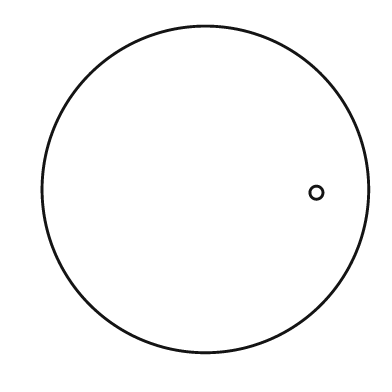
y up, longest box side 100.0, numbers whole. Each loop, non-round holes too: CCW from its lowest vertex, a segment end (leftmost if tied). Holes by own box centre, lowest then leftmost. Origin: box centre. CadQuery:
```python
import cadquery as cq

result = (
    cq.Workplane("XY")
    .moveTo(0.0, 0.0)
    .circle(50.0)
    .moveTo(34.0, -1.0)
    .circle(2.0)
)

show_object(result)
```